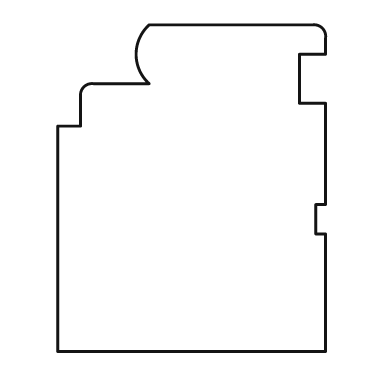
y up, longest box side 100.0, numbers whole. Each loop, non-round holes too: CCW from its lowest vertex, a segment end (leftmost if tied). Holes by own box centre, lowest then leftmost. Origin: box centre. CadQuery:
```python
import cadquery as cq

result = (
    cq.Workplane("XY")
    .moveTo(-41.0, -50.0)
    .lineTo(41.0, -50.0)
    .lineTo(41.0, -14.0)
    .lineTo(38.0, -14.0)
    .lineTo(38.0, -5.0)
    .lineTo(41.0, -5.0)
    .lineTo(41.0, 26.0)
    .lineTo(33.0, 26.0)
    .lineTo(33.0, 41.0)
    .lineTo(41.0, 41.0)
    .lineTo(41.0, 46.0)
    .threePointArc((40.0, 49.0), (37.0, 50.0))
    .lineTo(-13.0, 50.0)
    .threePointArc((-17.0, 41.0), (-13.0, 32.0))
    .lineTo(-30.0, 32.0)
    .threePointArc((-33.0, 31.0), (-34.0, 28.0))
    .lineTo(-34.0, 19.0)
    .lineTo(-41.0, 19.0)
    .close()
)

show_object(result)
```